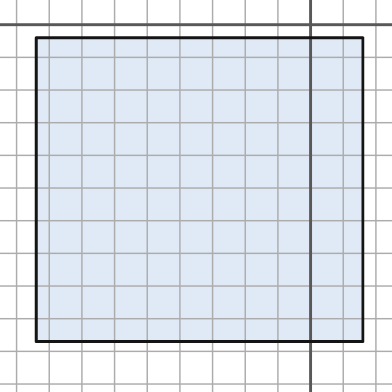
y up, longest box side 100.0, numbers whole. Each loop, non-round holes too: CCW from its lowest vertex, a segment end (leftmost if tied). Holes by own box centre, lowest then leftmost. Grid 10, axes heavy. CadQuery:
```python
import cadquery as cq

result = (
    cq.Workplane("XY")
    .moveTo(-84.0, -97.0)
    .lineTo(16.0, -97.0)
    .lineTo(16.0, -4.0)
    .lineTo(-84.0, -4.0)
    .close()
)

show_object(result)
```